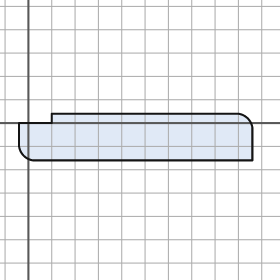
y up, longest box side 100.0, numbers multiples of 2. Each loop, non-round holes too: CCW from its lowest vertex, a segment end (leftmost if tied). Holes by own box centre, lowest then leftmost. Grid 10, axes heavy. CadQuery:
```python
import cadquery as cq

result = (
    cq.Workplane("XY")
    .moveTo(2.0, -16.0)
    .lineTo(96.0, -16.0)
    .lineTo(96.0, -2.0)
    .threePointArc((94.0, 2.0), (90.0, 4.0))
    .lineTo(10.0, 4.0)
    .lineTo(10.0, 0.0)
    .lineTo(-4.0, 0.0)
    .lineTo(-4.0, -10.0)
    .threePointArc((-2.0, -14.0), (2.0, -16.0))
    .close()
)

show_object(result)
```